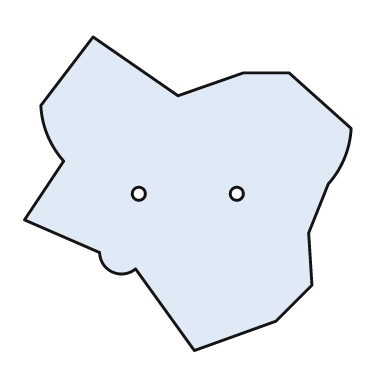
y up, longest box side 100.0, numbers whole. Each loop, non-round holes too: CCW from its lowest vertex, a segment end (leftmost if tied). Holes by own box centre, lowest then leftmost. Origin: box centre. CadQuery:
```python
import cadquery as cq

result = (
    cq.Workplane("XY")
    .moveTo(2.0, -48.0)
    .lineTo(27.0, -39.0)
    .lineTo(38.0, -28.0)
    .lineTo(37.0, -12.0)
    .lineTo(43.0, 3.0)
    .threePointArc((48.0, 11.0), (50.0, 20.0))
    .lineTo(31.0, 37.0)
    .lineTo(17.0, 37.0)
    .lineTo(-3.0, 30.0)
    .lineTo(-29.0, 48.0)
    .lineTo(-45.0, 27.0)
    .threePointArc((-43.0, 18.0), (-38.0, 10.0))
    .lineTo(-50.0, -8.0)
    .lineTo(-27.0, -18.0)
    .threePointArc((-23.0, -24.0), (-16.0, -23.0))
    .close()
    .moveTo(-15.0, 0.0)
    .circle(2.0)
    .moveTo(15.0, 0.0)
    .circle(2.0)
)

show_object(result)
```